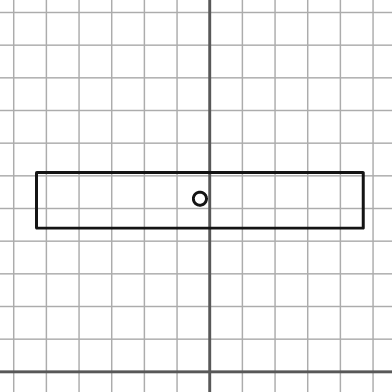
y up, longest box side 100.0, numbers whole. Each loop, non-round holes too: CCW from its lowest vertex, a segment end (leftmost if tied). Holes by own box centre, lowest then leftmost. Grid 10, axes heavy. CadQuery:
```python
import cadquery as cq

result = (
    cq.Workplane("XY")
    .moveTo(-53.0, 44.0)
    .lineTo(47.0, 44.0)
    .lineTo(47.0, 61.0)
    .lineTo(-53.0, 61.0)
    .close()
    .moveTo(-3.0, 53.0)
    .circle(2.0)
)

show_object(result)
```